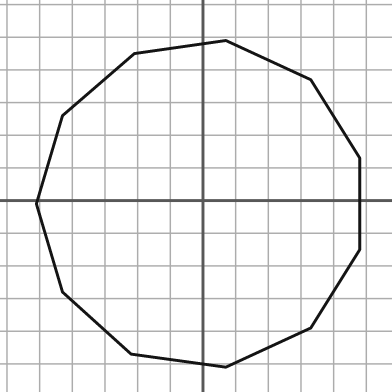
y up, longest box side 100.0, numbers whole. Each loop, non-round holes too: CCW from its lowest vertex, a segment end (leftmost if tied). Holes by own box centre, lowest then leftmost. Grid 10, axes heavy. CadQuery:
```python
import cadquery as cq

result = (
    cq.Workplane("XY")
    .moveTo(7.0, -51.0)
    .lineTo(33.0, -39.0)
    .lineTo(48.0, -15.0)
    .lineTo(48.0, 13.0)
    .lineTo(33.0, 37.0)
    .lineTo(7.0, 49.0)
    .lineTo(-21.0, 45.0)
    .lineTo(-43.0, 26.0)
    .lineTo(-51.0, -1.0)
    .lineTo(-43.0, -28.0)
    .lineTo(-22.0, -47.0)
    .close()
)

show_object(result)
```